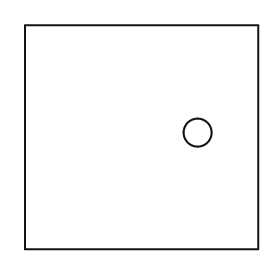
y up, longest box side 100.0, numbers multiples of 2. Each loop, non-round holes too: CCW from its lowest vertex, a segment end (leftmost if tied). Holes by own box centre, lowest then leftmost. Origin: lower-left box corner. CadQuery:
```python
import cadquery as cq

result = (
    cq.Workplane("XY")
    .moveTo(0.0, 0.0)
    .lineTo(100.0, 0.0)
    .lineTo(100.0, 96.0)
    .lineTo(0.0, 96.0)
    .close()
    .moveTo(74.0, 50.0)
    .circle(6.0)
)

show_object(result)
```